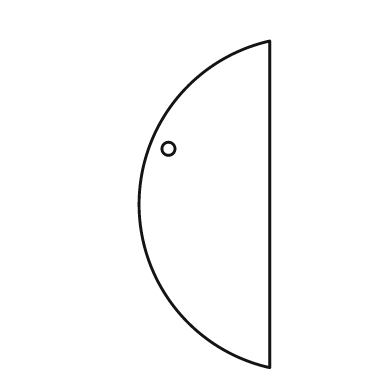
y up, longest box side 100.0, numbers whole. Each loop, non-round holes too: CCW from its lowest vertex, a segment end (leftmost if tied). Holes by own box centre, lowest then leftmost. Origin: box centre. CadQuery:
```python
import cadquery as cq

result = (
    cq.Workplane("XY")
    .moveTo(20.0, -50.0)
    .lineTo(20.0, 50.0)
    .threePointArc((-20.0, 0.0), (20.0, -50.0))
    .close()
    .moveTo(-11.0, 17.0)
    .circle(2.0)
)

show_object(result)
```